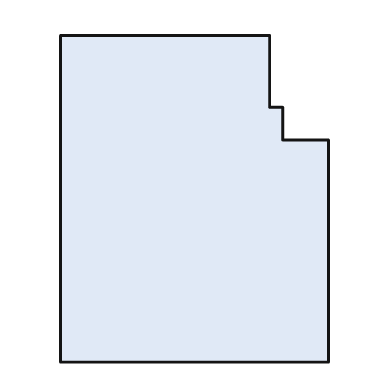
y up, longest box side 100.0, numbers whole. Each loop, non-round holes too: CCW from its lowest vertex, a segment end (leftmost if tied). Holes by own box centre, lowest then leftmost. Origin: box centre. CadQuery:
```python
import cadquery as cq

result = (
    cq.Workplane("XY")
    .moveTo(-41.0, -50.0)
    .lineTo(41.0, -50.0)
    .lineTo(41.0, 18.0)
    .lineTo(27.0, 18.0)
    .lineTo(27.0, 28.0)
    .lineTo(23.0, 28.0)
    .lineTo(23.0, 50.0)
    .lineTo(-41.0, 50.0)
    .close()
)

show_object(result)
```